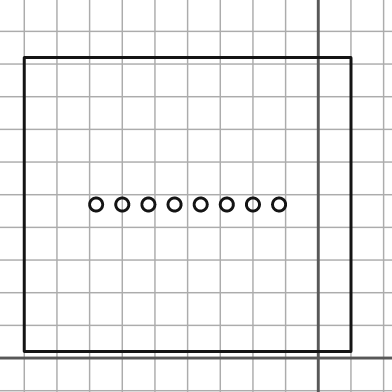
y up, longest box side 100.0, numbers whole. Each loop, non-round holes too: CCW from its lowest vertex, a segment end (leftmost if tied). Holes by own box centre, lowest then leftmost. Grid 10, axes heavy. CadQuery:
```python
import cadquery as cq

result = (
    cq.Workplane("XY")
    .moveTo(-90.0, 2.0)
    .lineTo(10.0, 2.0)
    .lineTo(10.0, 92.0)
    .lineTo(-90.0, 92.0)
    .close()
    .moveTo(-68.0, 47.0)
    .circle(2.0)
    .moveTo(-60.0, 47.0)
    .circle(2.0)
    .moveTo(-52.0, 47.0)
    .circle(2.0)
    .moveTo(-44.0, 47.0)
    .circle(2.0)
    .moveTo(-36.0, 47.0)
    .circle(2.0)
    .moveTo(-28.0, 47.0)
    .circle(2.0)
    .moveTo(-20.0, 47.0)
    .circle(2.0)
    .moveTo(-12.0, 47.0)
    .circle(2.0)
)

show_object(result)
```